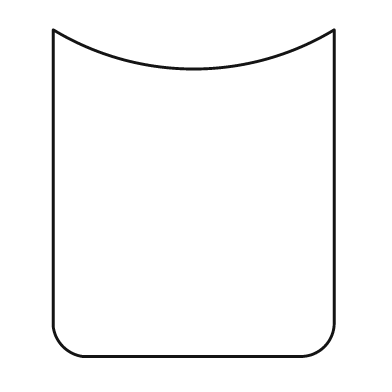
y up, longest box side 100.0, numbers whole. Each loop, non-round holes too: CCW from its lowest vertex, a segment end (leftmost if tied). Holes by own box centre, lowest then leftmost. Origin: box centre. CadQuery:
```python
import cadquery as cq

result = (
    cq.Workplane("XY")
    .moveTo(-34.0, -50.0)
    .lineTo(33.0, -50.0)
    .threePointArc((40.0, -47.0), (43.0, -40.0))
    .lineTo(43.0, 50.0)
    .threePointArc((0.0, 38.0), (-43.0, 50.0))
    .lineTo(-43.0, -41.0)
    .threePointArc((-40.0, -47.0), (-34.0, -50.0))
    .close()
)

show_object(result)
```